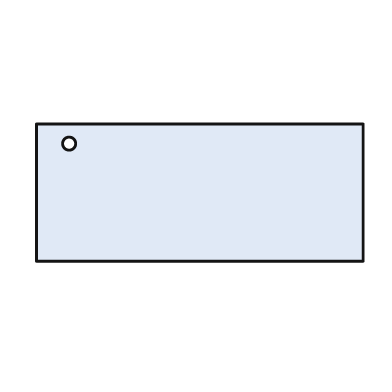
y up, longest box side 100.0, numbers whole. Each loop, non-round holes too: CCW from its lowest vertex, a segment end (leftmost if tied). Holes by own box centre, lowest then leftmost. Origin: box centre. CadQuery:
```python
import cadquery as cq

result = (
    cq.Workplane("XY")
    .moveTo(-50.0, -21.0)
    .lineTo(50.0, -21.0)
    .lineTo(50.0, 21.0)
    .lineTo(-50.0, 21.0)
    .close()
    .moveTo(-40.0, 15.0)
    .circle(2.0)
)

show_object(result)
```